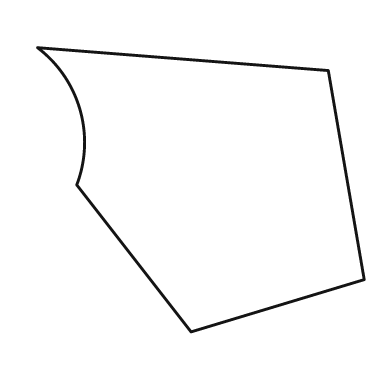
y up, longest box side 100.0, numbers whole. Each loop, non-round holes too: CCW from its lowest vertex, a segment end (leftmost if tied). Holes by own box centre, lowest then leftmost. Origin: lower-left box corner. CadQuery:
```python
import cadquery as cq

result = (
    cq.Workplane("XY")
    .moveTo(47.0, 0.0)
    .lineTo(100.0, 16.0)
    .lineTo(89.0, 80.0)
    .lineTo(0.0, 87.0)
    .threePointArc((13.0, 68.0), (12.0, 45.0))
    .close()
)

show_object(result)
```